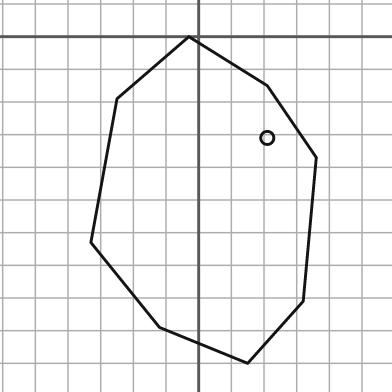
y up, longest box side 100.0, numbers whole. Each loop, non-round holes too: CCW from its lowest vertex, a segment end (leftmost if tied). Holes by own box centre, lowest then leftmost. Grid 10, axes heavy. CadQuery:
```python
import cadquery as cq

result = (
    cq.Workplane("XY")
    .moveTo(15.0, -100.0)
    .lineTo(32.0, -81.0)
    .lineTo(36.0, -37.0)
    .lineTo(21.0, -15.0)
    .lineTo(-3.0, 0.0)
    .lineTo(-25.0, -19.0)
    .lineTo(-33.0, -63.0)
    .lineTo(-12.0, -89.0)
    .close()
    .moveTo(21.0, -31.0)
    .circle(2.0)
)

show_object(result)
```